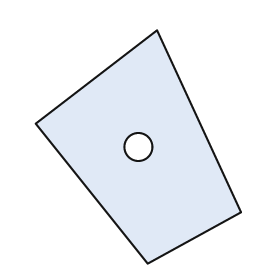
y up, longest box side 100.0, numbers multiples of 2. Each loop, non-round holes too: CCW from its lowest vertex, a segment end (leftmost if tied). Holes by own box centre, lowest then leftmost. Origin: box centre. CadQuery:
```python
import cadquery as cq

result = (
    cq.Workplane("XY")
    .moveTo(4.0, -50.0)
    .lineTo(44.0, -28.0)
    .lineTo(8.0, 50.0)
    .lineTo(-44.0, 10.0)
    .close()
    .moveTo(0.0, 0.0)
    .circle(6.0)
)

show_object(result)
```